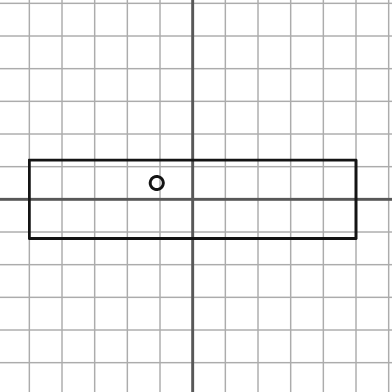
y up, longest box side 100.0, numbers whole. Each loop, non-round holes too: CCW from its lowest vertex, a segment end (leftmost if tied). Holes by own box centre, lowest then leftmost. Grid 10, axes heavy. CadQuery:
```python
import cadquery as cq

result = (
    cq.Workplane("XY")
    .moveTo(-50.0, -12.0)
    .lineTo(50.0, -12.0)
    .lineTo(50.0, 12.0)
    .lineTo(-50.0, 12.0)
    .close()
    .moveTo(-11.0, 5.0)
    .circle(2.0)
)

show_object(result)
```